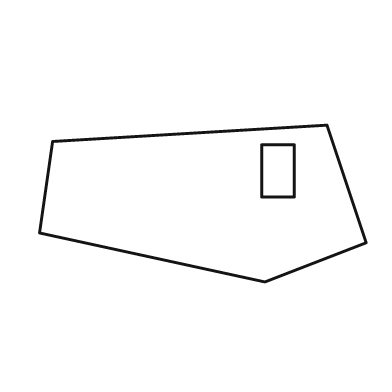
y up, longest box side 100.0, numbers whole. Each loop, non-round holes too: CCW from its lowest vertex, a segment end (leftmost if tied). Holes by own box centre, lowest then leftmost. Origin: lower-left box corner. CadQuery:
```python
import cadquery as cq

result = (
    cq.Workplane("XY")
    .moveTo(69.0, 0.0)
    .lineTo(100.0, 12.0)
    .lineTo(88.0, 48.0)
    .lineTo(4.0, 43.0)
    .lineTo(0.0, 15.0)
    .close()
    .moveTo(68.0, 26.0)
    .lineTo(78.0, 26.0)
    .lineTo(78.0, 42.0)
    .lineTo(68.0, 42.0)
    .close()
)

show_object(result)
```